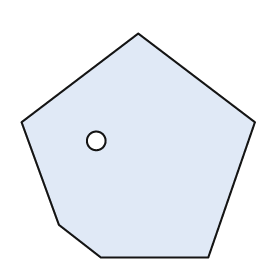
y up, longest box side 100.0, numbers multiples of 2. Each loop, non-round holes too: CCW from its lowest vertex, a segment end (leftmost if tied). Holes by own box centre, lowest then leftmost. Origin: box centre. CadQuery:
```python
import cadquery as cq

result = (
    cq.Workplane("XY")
    .moveTo(-16.0, -48.0)
    .lineTo(30.0, -48.0)
    .lineTo(50.0, 10.0)
    .lineTo(0.0, 48.0)
    .lineTo(-50.0, 10.0)
    .lineTo(-34.0, -34.0)
    .close()
    .moveTo(-18.0, 2.0)
    .circle(4.0)
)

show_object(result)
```